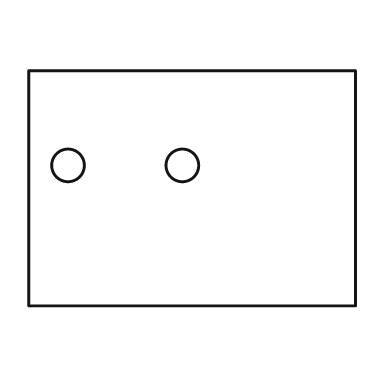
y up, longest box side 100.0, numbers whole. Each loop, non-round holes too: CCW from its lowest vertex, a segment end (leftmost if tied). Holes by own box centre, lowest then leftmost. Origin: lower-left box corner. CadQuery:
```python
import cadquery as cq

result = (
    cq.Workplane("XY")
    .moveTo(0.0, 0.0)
    .lineTo(100.0, 0.0)
    .lineTo(100.0, 72.0)
    .lineTo(0.0, 72.0)
    .close()
    .moveTo(12.0, 43.0)
    .circle(5.0)
    .moveTo(47.0, 43.0)
    .circle(5.0)
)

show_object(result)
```